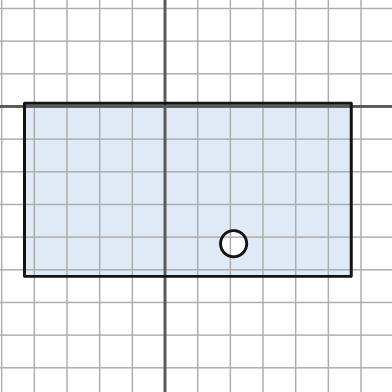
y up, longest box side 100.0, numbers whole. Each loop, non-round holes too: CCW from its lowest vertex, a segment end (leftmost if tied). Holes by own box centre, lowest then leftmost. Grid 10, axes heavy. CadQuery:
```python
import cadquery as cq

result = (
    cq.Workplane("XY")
    .moveTo(-43.0, -52.0)
    .lineTo(57.0, -52.0)
    .lineTo(57.0, 1.0)
    .lineTo(-43.0, 1.0)
    .close()
    .moveTo(21.0, -42.0)
    .circle(4.0)
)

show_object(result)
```